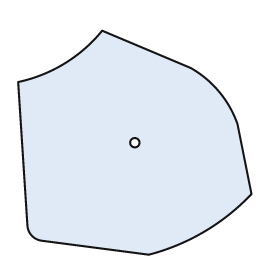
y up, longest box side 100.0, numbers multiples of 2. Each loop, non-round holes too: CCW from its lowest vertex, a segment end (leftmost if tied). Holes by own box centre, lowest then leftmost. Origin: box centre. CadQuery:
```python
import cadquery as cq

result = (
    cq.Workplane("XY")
    .moveTo(6.0, -48.0)
    .threePointArc((30.0, -38.0), (50.0, -22.0))
    .lineTo(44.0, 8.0)
    .threePointArc((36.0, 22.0), (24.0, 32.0))
    .lineTo(-14.0, 48.0)
    .threePointArc((-30.0, 34.0), (-50.0, 26.0))
    .lineTo(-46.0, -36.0)
    .threePointArc((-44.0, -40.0), (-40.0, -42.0))
    .close()
    .moveTo(0.0, 0.0)
    .circle(2.0)
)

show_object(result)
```